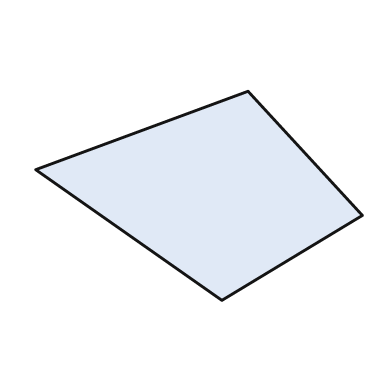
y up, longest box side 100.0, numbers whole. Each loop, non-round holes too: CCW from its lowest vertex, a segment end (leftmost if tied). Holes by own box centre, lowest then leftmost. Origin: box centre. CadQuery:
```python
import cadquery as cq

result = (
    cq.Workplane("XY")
    .moveTo(7.0, -32.0)
    .lineTo(50.0, -6.0)
    .lineTo(15.0, 32.0)
    .lineTo(-50.0, 8.0)
    .close()
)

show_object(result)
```